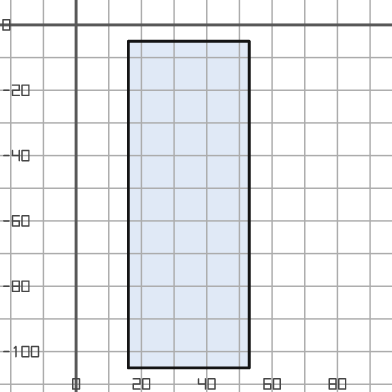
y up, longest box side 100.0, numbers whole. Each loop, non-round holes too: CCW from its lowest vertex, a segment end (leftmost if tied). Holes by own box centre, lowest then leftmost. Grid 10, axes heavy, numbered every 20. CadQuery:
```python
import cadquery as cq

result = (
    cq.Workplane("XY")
    .moveTo(16.0, -105.0)
    .lineTo(53.0, -105.0)
    .lineTo(53.0, -5.0)
    .lineTo(16.0, -5.0)
    .close()
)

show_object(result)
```